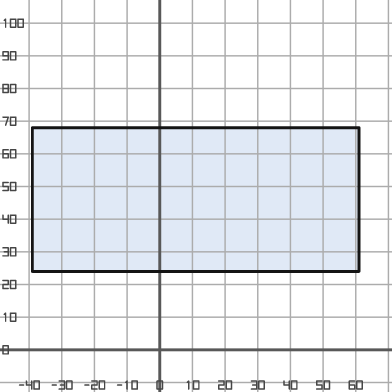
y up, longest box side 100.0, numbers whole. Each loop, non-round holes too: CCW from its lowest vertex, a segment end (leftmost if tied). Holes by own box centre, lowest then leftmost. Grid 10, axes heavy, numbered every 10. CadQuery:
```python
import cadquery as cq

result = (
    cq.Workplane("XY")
    .moveTo(-39.0, 24.0)
    .lineTo(61.0, 24.0)
    .lineTo(61.0, 68.0)
    .lineTo(-39.0, 68.0)
    .close()
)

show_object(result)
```